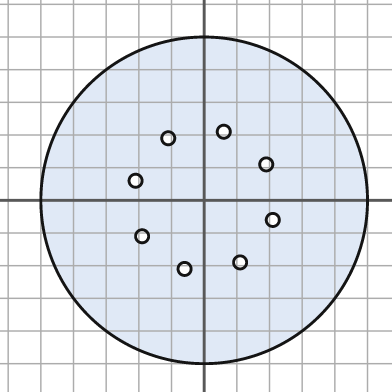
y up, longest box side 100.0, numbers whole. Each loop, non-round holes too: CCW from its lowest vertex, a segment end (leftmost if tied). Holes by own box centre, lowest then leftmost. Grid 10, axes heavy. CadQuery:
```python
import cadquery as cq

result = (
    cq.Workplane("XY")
    .moveTo(0.0, 0.0)
    .circle(50.0)
    .moveTo(-6.0, -21.0)
    .circle(2.0)
    .moveTo(11.0, -19.0)
    .circle(2.0)
    .moveTo(-19.0, -11.0)
    .circle(2.0)
    .moveTo(21.0, -6.0)
    .circle(2.0)
    .moveTo(-21.0, 6.0)
    .circle(2.0)
    .moveTo(19.0, 11.0)
    .circle(2.0)
    .moveTo(-11.0, 19.0)
    .circle(2.0)
    .moveTo(6.0, 21.0)
    .circle(2.0)
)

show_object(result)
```